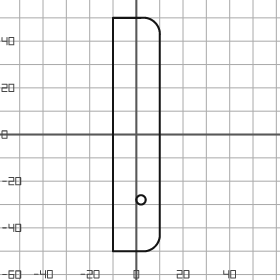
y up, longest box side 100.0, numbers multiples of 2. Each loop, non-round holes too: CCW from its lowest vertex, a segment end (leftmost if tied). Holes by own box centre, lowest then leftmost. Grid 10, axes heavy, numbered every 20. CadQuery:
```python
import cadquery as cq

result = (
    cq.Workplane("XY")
    .moveTo(-10.0, -50.0)
    .lineTo(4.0, -50.0)
    .threePointArc((8.0, -48.0), (10.0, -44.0))
    .lineTo(10.0, 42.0)
    .threePointArc((8.0, 48.0), (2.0, 50.0))
    .lineTo(-10.0, 50.0)
    .close()
    .moveTo(2.0, -28.0)
    .circle(2.0)
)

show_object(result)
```